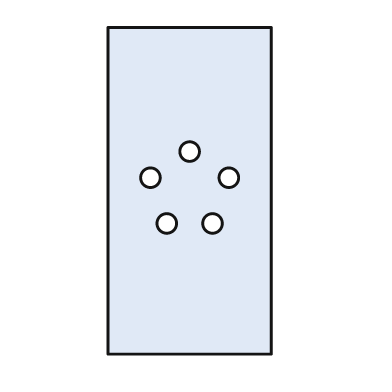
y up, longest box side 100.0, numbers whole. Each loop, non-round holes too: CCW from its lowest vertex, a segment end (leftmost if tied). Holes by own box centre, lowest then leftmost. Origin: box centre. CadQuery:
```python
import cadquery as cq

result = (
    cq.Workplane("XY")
    .moveTo(-25.0, -50.0)
    .lineTo(25.0, -50.0)
    .lineTo(25.0, 50.0)
    .lineTo(-25.0, 50.0)
    .close()
    .moveTo(-7.0, -10.0)
    .circle(3.0)
    .moveTo(7.0, -10.0)
    .circle(3.0)
    .moveTo(-12.0, 4.0)
    .circle(3.0)
    .moveTo(12.0, 4.0)
    .circle(3.0)
    .moveTo(0.0, 12.0)
    .circle(3.0)
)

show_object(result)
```